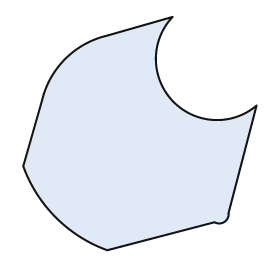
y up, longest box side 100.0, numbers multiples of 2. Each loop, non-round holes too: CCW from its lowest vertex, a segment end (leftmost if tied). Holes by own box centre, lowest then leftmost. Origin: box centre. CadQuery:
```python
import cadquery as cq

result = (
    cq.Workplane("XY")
    .moveTo(-14.0, -50.0)
    .lineTo(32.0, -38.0)
    .threePointArc((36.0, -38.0), (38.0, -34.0))
    .lineTo(50.0, 12.0)
    .threePointArc((14.0, 14.0), (14.0, 50.0))
    .lineTo(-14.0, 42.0)
    .threePointArc((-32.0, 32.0), (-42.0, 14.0))
    .lineTo(-50.0, -14.0)
    .threePointArc((-36.0, -36.0), (-14.0, -50.0))
    .close()
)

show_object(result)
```